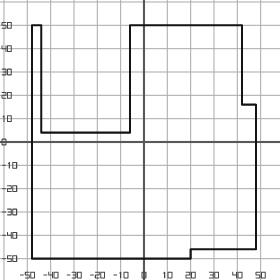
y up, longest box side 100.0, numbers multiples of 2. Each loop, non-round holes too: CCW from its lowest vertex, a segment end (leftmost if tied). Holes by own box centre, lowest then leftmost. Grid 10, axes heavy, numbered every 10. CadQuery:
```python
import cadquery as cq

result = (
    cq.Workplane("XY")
    .moveTo(-48.0, -50.0)
    .lineTo(20.0, -50.0)
    .lineTo(20.0, -46.0)
    .lineTo(48.0, -46.0)
    .lineTo(48.0, 16.0)
    .lineTo(42.0, 16.0)
    .lineTo(42.0, 50.0)
    .lineTo(-6.0, 50.0)
    .lineTo(-6.0, 4.0)
    .lineTo(-44.0, 4.0)
    .lineTo(-44.0, 50.0)
    .lineTo(-48.0, 50.0)
    .close()
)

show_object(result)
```